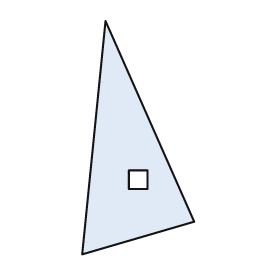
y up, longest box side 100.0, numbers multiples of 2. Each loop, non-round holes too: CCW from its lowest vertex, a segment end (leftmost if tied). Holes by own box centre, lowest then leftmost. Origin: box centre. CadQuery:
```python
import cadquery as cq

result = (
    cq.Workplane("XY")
    .moveTo(-24.0, -50.0)
    .lineTo(24.0, -36.0)
    .lineTo(-14.0, 50.0)
    .close()
    .moveTo(-4.0, -22.0)
    .lineTo(4.0, -22.0)
    .lineTo(4.0, -14.0)
    .lineTo(-4.0, -14.0)
    .close()
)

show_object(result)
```